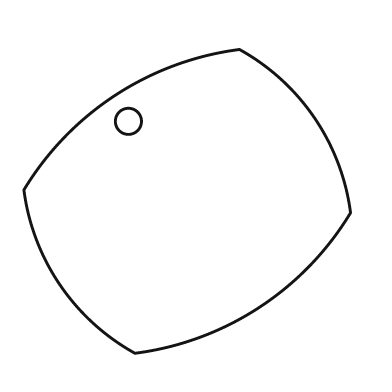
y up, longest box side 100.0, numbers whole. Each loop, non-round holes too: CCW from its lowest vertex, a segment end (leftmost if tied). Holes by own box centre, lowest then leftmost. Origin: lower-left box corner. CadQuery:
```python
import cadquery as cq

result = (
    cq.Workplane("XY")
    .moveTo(34.0, 0.0)
    .threePointArc((72.0, 14.0), (100.0, 43.0))
    .threePointArc((89.0, 72.0), (66.0, 93.0))
    .threePointArc((28.0, 79.0), (0.0, 50.0))
    .threePointArc((11.0, 21.0), (34.0, 0.0))
    .close()
    .moveTo(32.0, 71.0)
    .circle(4.0)
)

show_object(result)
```